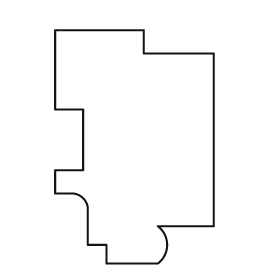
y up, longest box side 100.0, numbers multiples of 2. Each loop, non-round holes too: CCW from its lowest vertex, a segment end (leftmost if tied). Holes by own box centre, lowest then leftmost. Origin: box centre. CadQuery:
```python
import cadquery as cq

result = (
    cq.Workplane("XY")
    .moveTo(-12.0, -50.0)
    .lineTo(10.0, -50.0)
    .threePointArc((14.0, -42.0), (10.0, -34.0))
    .lineTo(34.0, -34.0)
    .lineTo(34.0, 40.0)
    .lineTo(4.0, 40.0)
    .lineTo(4.0, 50.0)
    .lineTo(-34.0, 50.0)
    .lineTo(-34.0, 16.0)
    .lineTo(-22.0, 16.0)
    .lineTo(-22.0, -10.0)
    .lineTo(-34.0, -10.0)
    .lineTo(-34.0, -20.0)
    .lineTo(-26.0, -20.0)
    .threePointArc((-22.0, -22.0), (-20.0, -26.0))
    .lineTo(-20.0, -42.0)
    .lineTo(-12.0, -42.0)
    .close()
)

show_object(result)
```